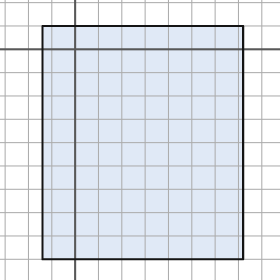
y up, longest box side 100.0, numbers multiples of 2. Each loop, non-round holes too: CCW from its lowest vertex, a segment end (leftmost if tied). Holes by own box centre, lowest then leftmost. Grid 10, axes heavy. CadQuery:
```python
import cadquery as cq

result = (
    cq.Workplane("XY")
    .moveTo(-14.0, -90.0)
    .lineTo(72.0, -90.0)
    .lineTo(72.0, 10.0)
    .lineTo(-14.0, 10.0)
    .close()
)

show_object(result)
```